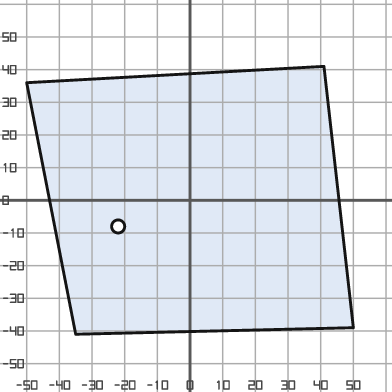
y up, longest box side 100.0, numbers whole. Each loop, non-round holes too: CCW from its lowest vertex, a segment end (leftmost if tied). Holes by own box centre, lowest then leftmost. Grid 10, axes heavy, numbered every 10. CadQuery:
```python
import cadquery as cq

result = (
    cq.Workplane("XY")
    .moveTo(-35.0, -41.0)
    .lineTo(50.0, -39.0)
    .lineTo(41.0, 41.0)
    .lineTo(-50.0, 36.0)
    .close()
    .moveTo(-22.0, -8.0)
    .circle(2.0)
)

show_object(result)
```